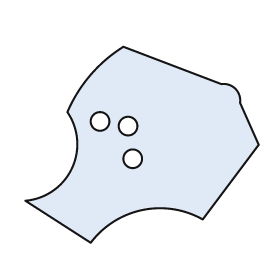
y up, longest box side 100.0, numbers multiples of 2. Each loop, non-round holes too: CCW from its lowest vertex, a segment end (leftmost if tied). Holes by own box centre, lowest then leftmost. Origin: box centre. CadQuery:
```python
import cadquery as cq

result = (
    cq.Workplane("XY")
    .moveTo(-22.0, -42.0)
    .threePointArc((0.0, -28.0), (26.0, -32.0))
    .lineTo(50.0, 0.0)
    .lineTo(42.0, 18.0)
    .threePointArc((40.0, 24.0), (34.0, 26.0))
    .lineTo(-8.0, 42.0)
    .threePointArc((-22.0, 30.0), (-32.0, 14.0))
    .threePointArc((-30.0, -10.0), (-50.0, -24.0))
    .close()
    .moveTo(-4.0, -6.0)
    .circle(4.0)
    .moveTo(-6.0, 8.0)
    .circle(4.0)
    .moveTo(-18.0, 10.0)
    .circle(4.0)
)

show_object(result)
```